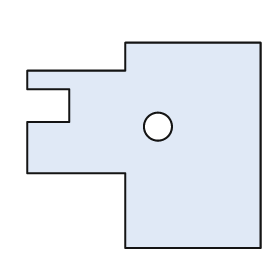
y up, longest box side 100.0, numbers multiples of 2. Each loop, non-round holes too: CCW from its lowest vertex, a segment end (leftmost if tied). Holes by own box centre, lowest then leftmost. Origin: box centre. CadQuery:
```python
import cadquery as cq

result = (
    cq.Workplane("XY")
    .moveTo(-8.0, -44.0)
    .lineTo(50.0, -44.0)
    .lineTo(50.0, 44.0)
    .lineTo(-8.0, 44.0)
    .lineTo(-8.0, 32.0)
    .lineTo(-50.0, 32.0)
    .lineTo(-50.0, 24.0)
    .lineTo(-32.0, 24.0)
    .lineTo(-32.0, 10.0)
    .lineTo(-50.0, 10.0)
    .lineTo(-50.0, -12.0)
    .lineTo(-8.0, -12.0)
    .close()
    .moveTo(6.0, 8.0)
    .circle(6.0)
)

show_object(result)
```